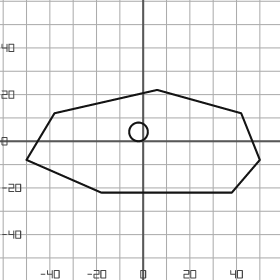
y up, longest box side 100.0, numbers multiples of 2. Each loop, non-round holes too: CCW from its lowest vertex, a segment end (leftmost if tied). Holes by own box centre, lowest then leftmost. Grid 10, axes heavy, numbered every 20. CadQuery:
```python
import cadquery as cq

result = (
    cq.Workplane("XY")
    .moveTo(-18.0, -22.0)
    .lineTo(38.0, -22.0)
    .lineTo(50.0, -8.0)
    .lineTo(42.0, 12.0)
    .lineTo(6.0, 22.0)
    .lineTo(-38.0, 12.0)
    .lineTo(-50.0, -8.0)
    .close()
    .moveTo(-2.0, 4.0)
    .circle(4.0)
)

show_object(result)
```